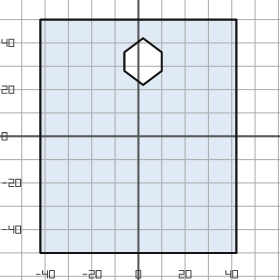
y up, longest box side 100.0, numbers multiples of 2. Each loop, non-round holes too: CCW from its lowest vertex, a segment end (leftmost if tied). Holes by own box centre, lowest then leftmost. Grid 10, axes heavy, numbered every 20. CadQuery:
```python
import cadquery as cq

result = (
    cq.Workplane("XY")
    .moveTo(-42.0, -50.0)
    .lineTo(42.0, -50.0)
    .lineTo(42.0, 50.0)
    .lineTo(-42.0, 50.0)
    .close()
    .moveTo(2.0, 22.0)
    .lineTo(10.0, 28.0)
    .lineTo(10.0, 36.0)
    .lineTo(2.0, 42.0)
    .lineTo(-6.0, 36.0)
    .lineTo(-6.0, 28.0)
    .close()
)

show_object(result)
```